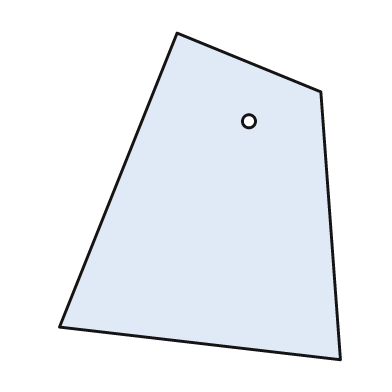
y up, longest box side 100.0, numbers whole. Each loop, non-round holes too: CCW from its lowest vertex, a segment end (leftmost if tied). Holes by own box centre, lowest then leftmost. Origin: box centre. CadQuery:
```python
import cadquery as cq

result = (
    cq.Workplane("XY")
    .moveTo(43.0, -50.0)
    .lineTo(37.0, 32.0)
    .lineTo(-7.0, 50.0)
    .lineTo(-43.0, -40.0)
    .close()
    .moveTo(15.0, 23.0)
    .circle(2.0)
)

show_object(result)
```